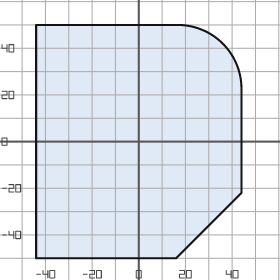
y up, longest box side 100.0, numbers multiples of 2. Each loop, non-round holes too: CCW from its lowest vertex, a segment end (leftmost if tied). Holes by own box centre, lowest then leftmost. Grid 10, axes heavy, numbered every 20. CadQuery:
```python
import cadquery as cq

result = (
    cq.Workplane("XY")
    .moveTo(-44.0, -50.0)
    .lineTo(16.0, -50.0)
    .lineTo(44.0, -22.0)
    .lineTo(44.0, 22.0)
    .threePointArc((36.0, 42.0), (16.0, 50.0))
    .lineTo(-44.0, 50.0)
    .close()
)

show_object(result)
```